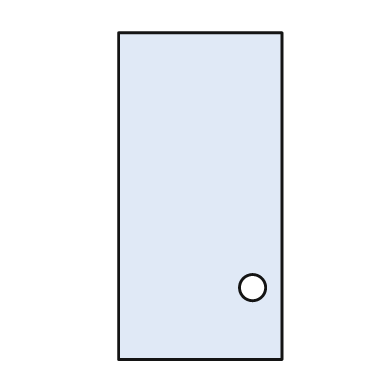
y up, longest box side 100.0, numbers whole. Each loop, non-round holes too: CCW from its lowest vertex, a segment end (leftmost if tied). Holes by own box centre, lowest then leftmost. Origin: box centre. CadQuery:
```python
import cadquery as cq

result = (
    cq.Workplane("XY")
    .moveTo(-25.0, -50.0)
    .lineTo(25.0, -50.0)
    .lineTo(25.0, 50.0)
    .lineTo(-25.0, 50.0)
    .close()
    .moveTo(16.0, -28.0)
    .circle(4.0)
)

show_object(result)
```